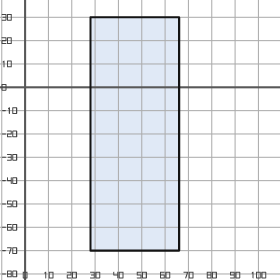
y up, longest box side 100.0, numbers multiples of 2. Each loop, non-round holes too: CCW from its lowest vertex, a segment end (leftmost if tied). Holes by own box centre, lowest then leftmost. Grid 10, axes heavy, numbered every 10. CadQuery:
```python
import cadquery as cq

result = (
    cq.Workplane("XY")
    .moveTo(28.0, -70.0)
    .lineTo(66.0, -70.0)
    .lineTo(66.0, 30.0)
    .lineTo(28.0, 30.0)
    .close()
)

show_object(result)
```